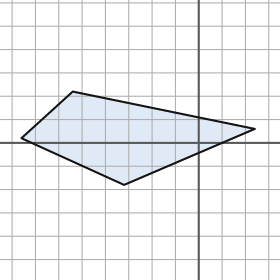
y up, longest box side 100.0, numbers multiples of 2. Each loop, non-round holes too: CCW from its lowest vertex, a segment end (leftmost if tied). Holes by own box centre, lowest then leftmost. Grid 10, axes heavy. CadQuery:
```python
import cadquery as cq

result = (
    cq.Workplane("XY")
    .moveTo(-32.0, -18.0)
    .lineTo(24.0, 6.0)
    .lineTo(-54.0, 22.0)
    .lineTo(-76.0, 2.0)
    .close()
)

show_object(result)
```